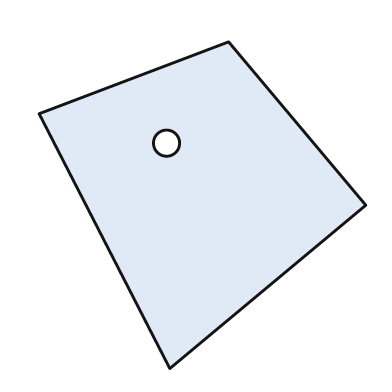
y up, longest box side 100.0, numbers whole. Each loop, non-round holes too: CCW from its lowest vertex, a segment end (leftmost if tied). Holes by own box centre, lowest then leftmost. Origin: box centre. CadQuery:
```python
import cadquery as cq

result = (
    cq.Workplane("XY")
    .moveTo(-10.0, -50.0)
    .lineTo(50.0, 0.0)
    .lineTo(8.0, 50.0)
    .lineTo(-50.0, 28.0)
    .close()
    .moveTo(-11.0, 19.0)
    .circle(4.0)
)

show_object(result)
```